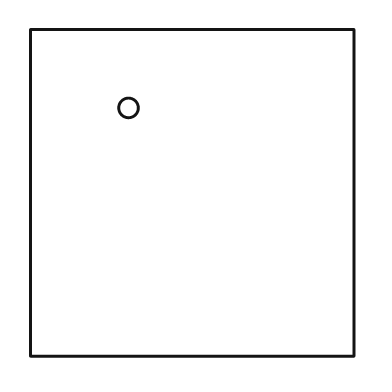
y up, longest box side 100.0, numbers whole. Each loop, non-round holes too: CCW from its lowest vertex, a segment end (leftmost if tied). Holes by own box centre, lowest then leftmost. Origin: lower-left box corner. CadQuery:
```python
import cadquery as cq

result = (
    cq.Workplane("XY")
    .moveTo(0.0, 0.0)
    .lineTo(99.0, 0.0)
    .lineTo(99.0, 100.0)
    .lineTo(0.0, 100.0)
    .close()
    .moveTo(30.0, 76.0)
    .circle(3.0)
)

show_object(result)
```